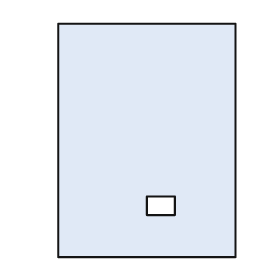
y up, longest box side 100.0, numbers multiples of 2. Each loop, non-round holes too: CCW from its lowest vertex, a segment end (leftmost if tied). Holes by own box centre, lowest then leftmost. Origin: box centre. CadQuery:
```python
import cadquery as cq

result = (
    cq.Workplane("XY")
    .moveTo(-38.0, -50.0)
    .lineTo(38.0, -50.0)
    .lineTo(38.0, 50.0)
    .lineTo(-38.0, 50.0)
    .close()
    .moveTo(0.0, -32.0)
    .lineTo(12.0, -32.0)
    .lineTo(12.0, -24.0)
    .lineTo(0.0, -24.0)
    .close()
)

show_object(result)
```